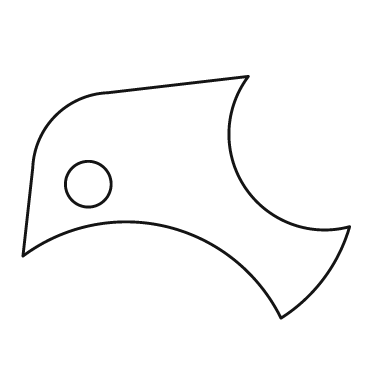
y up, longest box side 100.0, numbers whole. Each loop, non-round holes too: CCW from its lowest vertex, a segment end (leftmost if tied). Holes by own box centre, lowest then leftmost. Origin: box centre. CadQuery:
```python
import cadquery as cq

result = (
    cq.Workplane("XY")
    .moveTo(29.0, -37.0)
    .threePointArc((42.0, -25.0), (50.0, -9.0))
    .threePointArc((18.0, 3.0), (19.0, 37.0))
    .lineTo(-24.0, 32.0)
    .threePointArc((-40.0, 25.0), (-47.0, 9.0))
    .lineTo(-50.0, -18.0)
    .threePointArc((-6.0, -9.0), (29.0, -37.0))
    .close()
    .moveTo(-30.0, 4.0)
    .circle(7.0)
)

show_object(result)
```